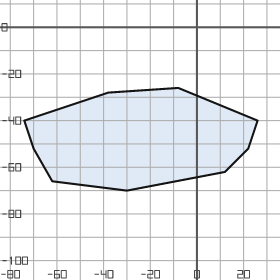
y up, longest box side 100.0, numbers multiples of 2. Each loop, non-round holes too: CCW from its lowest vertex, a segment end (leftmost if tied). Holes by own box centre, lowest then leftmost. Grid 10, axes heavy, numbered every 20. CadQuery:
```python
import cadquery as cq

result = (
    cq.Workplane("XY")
    .moveTo(-30.0, -70.0)
    .lineTo(12.0, -62.0)
    .lineTo(22.0, -52.0)
    .lineTo(26.0, -40.0)
    .lineTo(-8.0, -26.0)
    .lineTo(-38.0, -28.0)
    .lineTo(-74.0, -40.0)
    .lineTo(-70.0, -52.0)
    .lineTo(-62.0, -66.0)
    .close()
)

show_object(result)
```